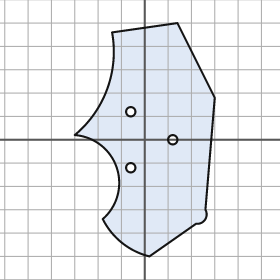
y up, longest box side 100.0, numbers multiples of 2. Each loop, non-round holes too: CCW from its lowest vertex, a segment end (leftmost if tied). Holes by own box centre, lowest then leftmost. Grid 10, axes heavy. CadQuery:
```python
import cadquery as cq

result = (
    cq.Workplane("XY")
    .moveTo(2.0, -50.0)
    .lineTo(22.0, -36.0)
    .threePointArc((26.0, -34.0), (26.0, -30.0))
    .lineTo(30.0, 18.0)
    .lineTo(14.0, 50.0)
    .lineTo(-14.0, 46.0)
    .threePointArc((-16.0, 22.0), (-30.0, 2.0))
    .threePointArc((-12.0, -12.0), (-18.0, -34.0))
    .threePointArc((-10.0, -44.0), (2.0, -50.0))
    .close()
    .moveTo(-6.0, -12.0)
    .circle(2.0)
    .moveTo(12.0, 0.0)
    .circle(2.0)
    .moveTo(-6.0, 12.0)
    .circle(2.0)
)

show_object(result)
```